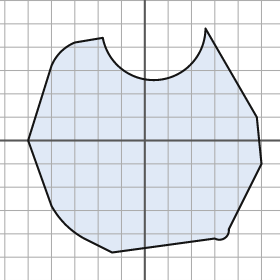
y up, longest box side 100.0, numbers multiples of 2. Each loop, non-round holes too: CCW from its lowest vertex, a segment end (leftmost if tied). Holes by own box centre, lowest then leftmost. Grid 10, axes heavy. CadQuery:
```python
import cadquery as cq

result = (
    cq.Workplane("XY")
    .moveTo(-14.0, -48.0)
    .lineTo(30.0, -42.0)
    .threePointArc((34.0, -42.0), (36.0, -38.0))
    .lineTo(50.0, -10.0)
    .lineTo(48.0, 10.0)
    .lineTo(26.0, 48.0)
    .threePointArc((6.0, 26.0), (-18.0, 44.0))
    .lineTo(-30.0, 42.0)
    .threePointArc((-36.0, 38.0), (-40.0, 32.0))
    .lineTo(-50.0, 0.0)
    .lineTo(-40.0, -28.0)
    .threePointArc((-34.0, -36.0), (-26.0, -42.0))
    .close()
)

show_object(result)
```